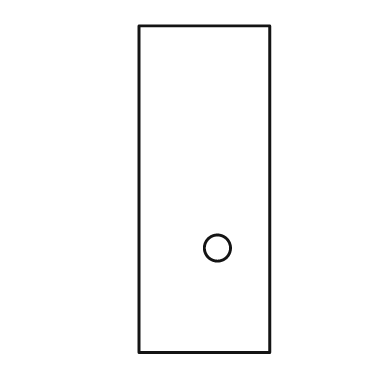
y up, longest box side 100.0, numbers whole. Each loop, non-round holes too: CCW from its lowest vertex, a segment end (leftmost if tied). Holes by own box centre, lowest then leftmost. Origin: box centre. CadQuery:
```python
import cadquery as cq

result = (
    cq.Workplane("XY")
    .moveTo(-20.0, -50.0)
    .lineTo(20.0, -50.0)
    .lineTo(20.0, 50.0)
    .lineTo(-20.0, 50.0)
    .close()
    .moveTo(4.0, -18.0)
    .circle(4.0)
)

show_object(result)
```